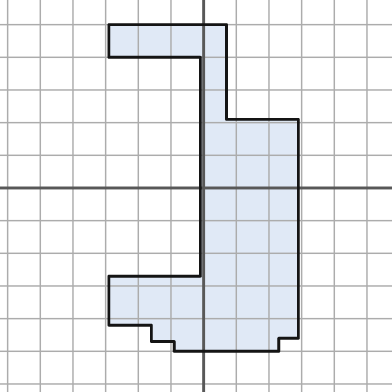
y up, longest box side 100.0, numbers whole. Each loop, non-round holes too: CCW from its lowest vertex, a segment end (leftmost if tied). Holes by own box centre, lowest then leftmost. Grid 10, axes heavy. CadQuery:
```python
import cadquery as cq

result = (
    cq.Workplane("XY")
    .moveTo(-9.0, -50.0)
    .lineTo(23.0, -50.0)
    .lineTo(23.0, -46.0)
    .lineTo(29.0, -46.0)
    .lineTo(29.0, 21.0)
    .lineTo(7.0, 21.0)
    .lineTo(7.0, 50.0)
    .lineTo(-29.0, 50.0)
    .lineTo(-29.0, 40.0)
    .lineTo(-1.0, 40.0)
    .lineTo(-1.0, -27.0)
    .lineTo(-29.0, -27.0)
    .lineTo(-29.0, -42.0)
    .lineTo(-16.0, -42.0)
    .lineTo(-16.0, -47.0)
    .lineTo(-9.0, -47.0)
    .close()
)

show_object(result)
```